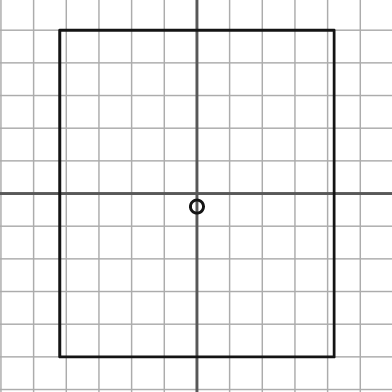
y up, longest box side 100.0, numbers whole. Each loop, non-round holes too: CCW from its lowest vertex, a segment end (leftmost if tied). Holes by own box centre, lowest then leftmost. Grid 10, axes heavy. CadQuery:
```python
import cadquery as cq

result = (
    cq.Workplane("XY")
    .moveTo(-42.0, -50.0)
    .lineTo(42.0, -50.0)
    .lineTo(42.0, 50.0)
    .lineTo(-42.0, 50.0)
    .close()
    .moveTo(0.0, -4.0)
    .circle(2.0)
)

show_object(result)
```